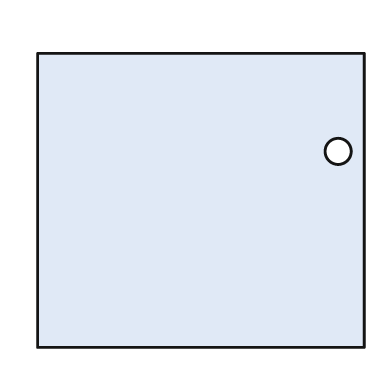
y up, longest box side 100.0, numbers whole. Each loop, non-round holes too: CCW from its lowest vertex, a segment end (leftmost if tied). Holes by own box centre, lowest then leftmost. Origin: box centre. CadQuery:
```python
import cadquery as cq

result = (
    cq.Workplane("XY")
    .moveTo(-50.0, -45.0)
    .lineTo(50.0, -45.0)
    .lineTo(50.0, 45.0)
    .lineTo(-50.0, 45.0)
    .close()
    .moveTo(42.0, 15.0)
    .circle(4.0)
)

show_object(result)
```